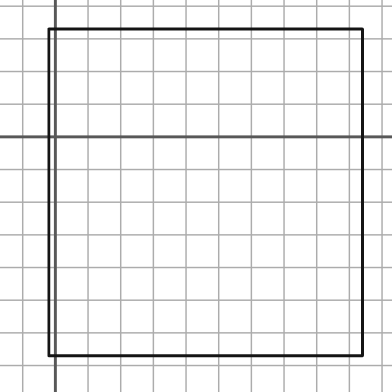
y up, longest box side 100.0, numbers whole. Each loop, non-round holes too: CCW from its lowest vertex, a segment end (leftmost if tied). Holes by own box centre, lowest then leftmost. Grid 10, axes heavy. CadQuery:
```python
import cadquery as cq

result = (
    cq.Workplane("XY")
    .moveTo(-2.0, -67.0)
    .lineTo(94.0, -67.0)
    .lineTo(94.0, 33.0)
    .lineTo(-2.0, 33.0)
    .close()
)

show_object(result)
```